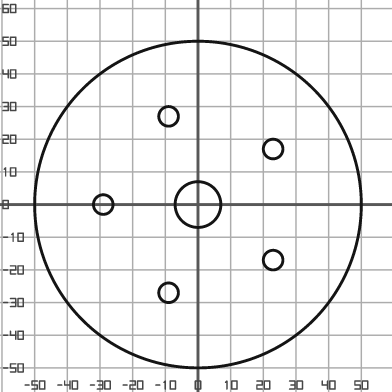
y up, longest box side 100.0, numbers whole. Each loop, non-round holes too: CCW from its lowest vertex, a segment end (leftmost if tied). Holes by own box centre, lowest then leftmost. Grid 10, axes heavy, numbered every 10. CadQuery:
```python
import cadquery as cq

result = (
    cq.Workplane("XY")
    .moveTo(0.0, 0.0)
    .circle(50.0)
    .moveTo(-9.0, -27.0)
    .circle(3.0)
    .moveTo(23.0, -17.0)
    .circle(3.0)
    .moveTo(-29.0, 0.0)
    .circle(3.0)
    .moveTo(0.0, 0.0)
    .circle(7.0)
    .moveTo(23.0, 17.0)
    .circle(3.0)
    .moveTo(-9.0, 27.0)
    .circle(3.0)
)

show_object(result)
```